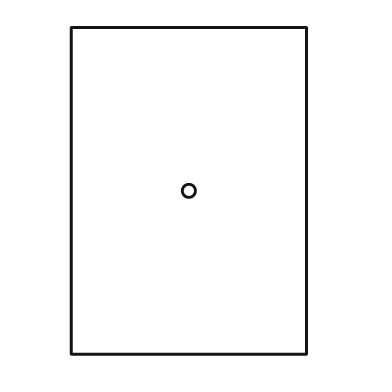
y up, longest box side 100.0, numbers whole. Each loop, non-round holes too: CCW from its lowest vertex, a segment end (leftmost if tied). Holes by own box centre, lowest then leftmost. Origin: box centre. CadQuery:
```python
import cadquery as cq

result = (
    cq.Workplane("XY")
    .moveTo(-36.0, -50.0)
    .lineTo(36.0, -50.0)
    .lineTo(36.0, 50.0)
    .lineTo(-36.0, 50.0)
    .close()
    .moveTo(0.0, 0.0)
    .circle(2.0)
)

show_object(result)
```